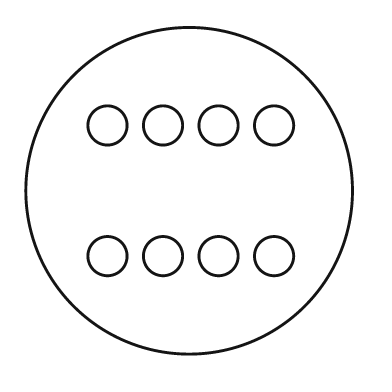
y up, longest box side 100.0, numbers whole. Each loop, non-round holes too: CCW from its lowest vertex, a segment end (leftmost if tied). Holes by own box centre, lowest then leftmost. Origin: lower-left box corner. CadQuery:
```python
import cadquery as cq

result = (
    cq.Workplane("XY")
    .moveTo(50.0, 50.0)
    .circle(50.0)
    .moveTo(25.0, 30.0)
    .circle(6.0)
    .moveTo(42.0, 30.0)
    .circle(6.0)
    .moveTo(59.0, 30.0)
    .circle(6.0)
    .moveTo(76.0, 30.0)
    .circle(6.0)
    .moveTo(25.0, 70.0)
    .circle(6.0)
    .moveTo(42.0, 70.0)
    .circle(6.0)
    .moveTo(59.0, 70.0)
    .circle(6.0)
    .moveTo(76.0, 70.0)
    .circle(6.0)
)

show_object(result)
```